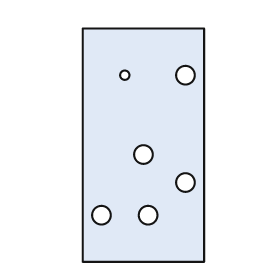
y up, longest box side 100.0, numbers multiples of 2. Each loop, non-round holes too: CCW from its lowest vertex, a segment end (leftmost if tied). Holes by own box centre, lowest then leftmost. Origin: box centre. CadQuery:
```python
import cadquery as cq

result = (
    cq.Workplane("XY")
    .moveTo(-26.0, -50.0)
    .lineTo(26.0, -50.0)
    .lineTo(26.0, 50.0)
    .lineTo(-26.0, 50.0)
    .close()
    .moveTo(-18.0, -30.0)
    .circle(4.0)
    .moveTo(2.0, -30.0)
    .circle(4.0)
    .moveTo(18.0, -16.0)
    .circle(4.0)
    .moveTo(0.0, -4.0)
    .circle(4.0)
    .moveTo(-8.0, 30.0)
    .circle(2.0)
    .moveTo(18.0, 30.0)
    .circle(4.0)
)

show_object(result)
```